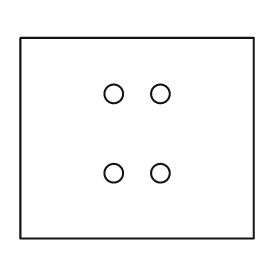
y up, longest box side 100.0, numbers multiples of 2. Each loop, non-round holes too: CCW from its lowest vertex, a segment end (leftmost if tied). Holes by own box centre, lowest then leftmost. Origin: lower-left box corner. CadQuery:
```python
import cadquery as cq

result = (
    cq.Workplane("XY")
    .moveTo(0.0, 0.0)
    .lineTo(100.0, 0.0)
    .lineTo(100.0, 86.0)
    .lineTo(0.0, 86.0)
    .close()
    .moveTo(40.0, 28.0)
    .circle(4.0)
    .moveTo(60.0, 28.0)
    .circle(4.0)
    .moveTo(40.0, 62.0)
    .circle(4.0)
    .moveTo(60.0, 62.0)
    .circle(4.0)
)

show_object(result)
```